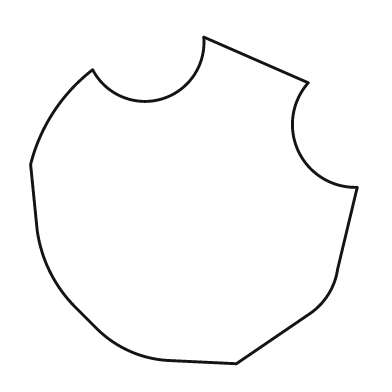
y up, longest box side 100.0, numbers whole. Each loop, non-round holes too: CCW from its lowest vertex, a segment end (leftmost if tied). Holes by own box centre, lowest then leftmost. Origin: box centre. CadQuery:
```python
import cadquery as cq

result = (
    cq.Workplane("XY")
    .moveTo(13.0, -50.0)
    .lineTo(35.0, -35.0)
    .threePointArc((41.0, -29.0), (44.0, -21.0))
    .lineTo(50.0, 4.0)
    .threePointArc((32.0, 15.0), (35.0, 36.0))
    .lineTo(3.0, 50.0)
    .threePointArc((-10.0, 31.0), (-31.0, 40.0))
    .threePointArc((-43.0, 27.0), (-50.0, 11.0))
    .lineTo(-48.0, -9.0)
    .threePointArc((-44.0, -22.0), (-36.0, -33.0))
    .lineTo(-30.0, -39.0)
    .threePointArc((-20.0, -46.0), (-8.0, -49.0))
    .close()
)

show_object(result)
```